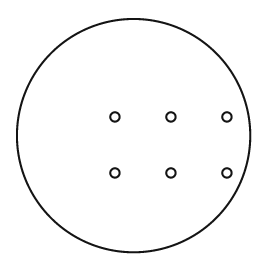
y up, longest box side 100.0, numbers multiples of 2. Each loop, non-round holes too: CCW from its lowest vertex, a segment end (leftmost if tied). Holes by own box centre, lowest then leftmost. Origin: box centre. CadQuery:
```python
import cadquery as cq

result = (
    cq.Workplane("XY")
    .moveTo(0.0, 0.0)
    .circle(50.0)
    .moveTo(-8.0, -16.0)
    .circle(2.0)
    .moveTo(16.0, -16.0)
    .circle(2.0)
    .moveTo(40.0, -16.0)
    .circle(2.0)
    .moveTo(-8.0, 8.0)
    .circle(2.0)
    .moveTo(16.0, 8.0)
    .circle(2.0)
    .moveTo(40.0, 8.0)
    .circle(2.0)
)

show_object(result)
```